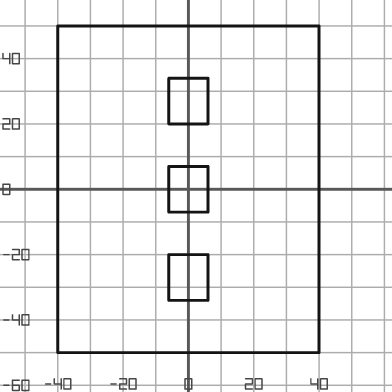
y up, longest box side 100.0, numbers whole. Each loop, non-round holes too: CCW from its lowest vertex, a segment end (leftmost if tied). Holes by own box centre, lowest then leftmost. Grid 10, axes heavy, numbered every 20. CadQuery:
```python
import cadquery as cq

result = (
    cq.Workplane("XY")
    .moveTo(-40.0, -50.0)
    .lineTo(40.0, -50.0)
    .lineTo(40.0, 50.0)
    .lineTo(-40.0, 50.0)
    .close()
    .moveTo(-6.0, -34.0)
    .lineTo(6.0, -34.0)
    .lineTo(6.0, -20.0)
    .lineTo(-6.0, -20.0)
    .close()
    .moveTo(-6.0, -7.0)
    .lineTo(6.0, -7.0)
    .lineTo(6.0, 7.0)
    .lineTo(-6.0, 7.0)
    .close()
    .moveTo(-6.0, 20.0)
    .lineTo(6.0, 20.0)
    .lineTo(6.0, 34.0)
    .lineTo(-6.0, 34.0)
    .close()
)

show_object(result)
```